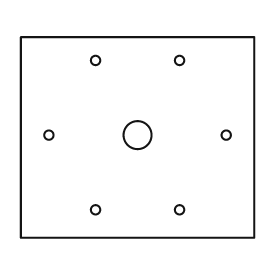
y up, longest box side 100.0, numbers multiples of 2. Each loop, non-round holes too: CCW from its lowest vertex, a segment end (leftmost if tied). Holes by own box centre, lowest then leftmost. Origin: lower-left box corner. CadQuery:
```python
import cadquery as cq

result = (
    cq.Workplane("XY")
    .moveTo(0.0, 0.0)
    .lineTo(100.0, 0.0)
    .lineTo(100.0, 86.0)
    .lineTo(0.0, 86.0)
    .close()
    .moveTo(32.0, 12.0)
    .circle(2.0)
    .moveTo(68.0, 12.0)
    .circle(2.0)
    .moveTo(12.0, 44.0)
    .circle(2.0)
    .moveTo(50.0, 44.0)
    .circle(6.0)
    .moveTo(88.0, 44.0)
    .circle(2.0)
    .moveTo(32.0, 76.0)
    .circle(2.0)
    .moveTo(68.0, 76.0)
    .circle(2.0)
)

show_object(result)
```